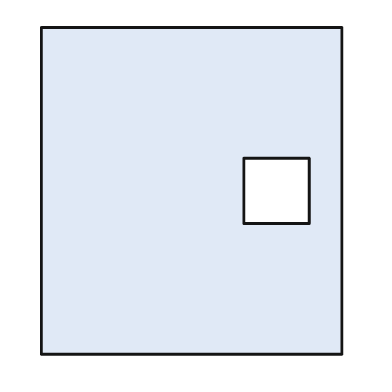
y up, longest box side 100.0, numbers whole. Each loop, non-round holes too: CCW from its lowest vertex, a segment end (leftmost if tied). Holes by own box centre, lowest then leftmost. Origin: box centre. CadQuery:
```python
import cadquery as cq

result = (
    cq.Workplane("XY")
    .moveTo(-46.0, -50.0)
    .lineTo(46.0, -50.0)
    .lineTo(46.0, 50.0)
    .lineTo(-46.0, 50.0)
    .close()
    .moveTo(16.0, -10.0)
    .lineTo(36.0, -10.0)
    .lineTo(36.0, 10.0)
    .lineTo(16.0, 10.0)
    .close()
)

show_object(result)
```